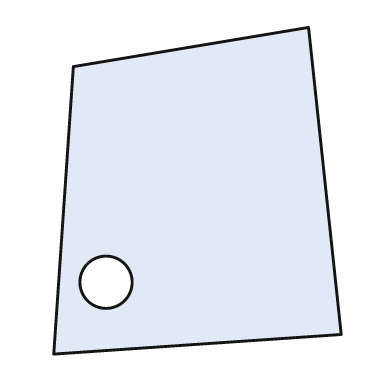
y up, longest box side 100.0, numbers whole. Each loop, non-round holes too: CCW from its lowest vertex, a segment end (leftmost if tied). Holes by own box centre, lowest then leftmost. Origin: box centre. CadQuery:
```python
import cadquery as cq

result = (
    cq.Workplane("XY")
    .moveTo(-44.0, -50.0)
    .lineTo(44.0, -44.0)
    .lineTo(34.0, 50.0)
    .lineTo(-38.0, 38.0)
    .close()
    .moveTo(-28.0, -28.0)
    .circle(8.0)
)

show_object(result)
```